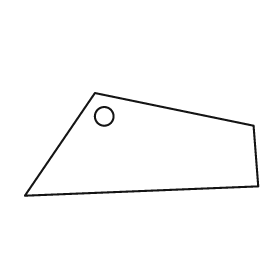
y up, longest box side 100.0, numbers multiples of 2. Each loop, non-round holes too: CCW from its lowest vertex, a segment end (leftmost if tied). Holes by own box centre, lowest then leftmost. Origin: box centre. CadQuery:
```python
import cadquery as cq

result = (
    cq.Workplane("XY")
    .moveTo(-50.0, -22.0)
    .lineTo(50.0, -18.0)
    .lineTo(48.0, 8.0)
    .lineTo(-20.0, 22.0)
    .close()
    .moveTo(-16.0, 12.0)
    .circle(4.0)
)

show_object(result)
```